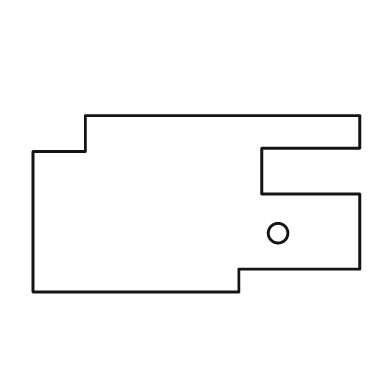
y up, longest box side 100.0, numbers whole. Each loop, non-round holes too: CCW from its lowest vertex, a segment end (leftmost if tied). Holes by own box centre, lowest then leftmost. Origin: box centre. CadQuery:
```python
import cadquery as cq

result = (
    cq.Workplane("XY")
    .moveTo(-50.0, -27.0)
    .lineTo(13.0, -27.0)
    .lineTo(13.0, -20.0)
    .lineTo(50.0, -20.0)
    .lineTo(50.0, 3.0)
    .lineTo(20.0, 3.0)
    .lineTo(20.0, 17.0)
    .lineTo(50.0, 17.0)
    .lineTo(50.0, 27.0)
    .lineTo(-34.0, 27.0)
    .lineTo(-34.0, 16.0)
    .lineTo(-50.0, 16.0)
    .close()
    .moveTo(25.0, -9.0)
    .circle(3.0)
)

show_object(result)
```